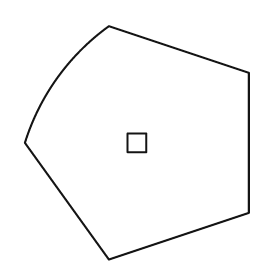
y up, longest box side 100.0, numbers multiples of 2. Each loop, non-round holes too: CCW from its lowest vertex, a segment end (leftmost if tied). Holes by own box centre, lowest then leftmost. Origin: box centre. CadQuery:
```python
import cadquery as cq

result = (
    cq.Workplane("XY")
    .moveTo(-12.0, -50.0)
    .lineTo(48.0, -30.0)
    .lineTo(48.0, 30.0)
    .lineTo(-12.0, 50.0)
    .threePointArc((-34.0, 28.0), (-48.0, 0.0))
    .close()
    .moveTo(-4.0, -4.0)
    .lineTo(4.0, -4.0)
    .lineTo(4.0, 4.0)
    .lineTo(-4.0, 4.0)
    .close()
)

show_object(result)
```